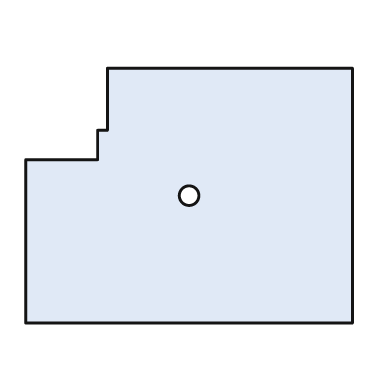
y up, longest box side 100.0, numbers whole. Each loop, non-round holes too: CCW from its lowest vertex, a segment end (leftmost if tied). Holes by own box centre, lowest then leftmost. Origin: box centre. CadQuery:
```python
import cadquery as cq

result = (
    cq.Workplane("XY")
    .moveTo(-50.0, -39.0)
    .lineTo(50.0, -39.0)
    .lineTo(50.0, 39.0)
    .lineTo(-25.0, 39.0)
    .lineTo(-25.0, 20.0)
    .lineTo(-28.0, 20.0)
    .lineTo(-28.0, 11.0)
    .lineTo(-50.0, 11.0)
    .close()
    .moveTo(0.0, 0.0)
    .circle(3.0)
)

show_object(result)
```